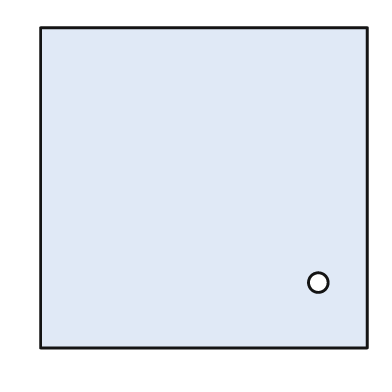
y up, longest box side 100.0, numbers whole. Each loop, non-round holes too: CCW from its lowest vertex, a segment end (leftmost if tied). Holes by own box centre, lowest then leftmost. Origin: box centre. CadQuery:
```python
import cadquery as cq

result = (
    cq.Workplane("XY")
    .moveTo(-50.0, -49.0)
    .lineTo(50.0, -49.0)
    .lineTo(50.0, 49.0)
    .lineTo(-50.0, 49.0)
    .close()
    .moveTo(35.0, -29.0)
    .circle(3.0)
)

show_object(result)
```